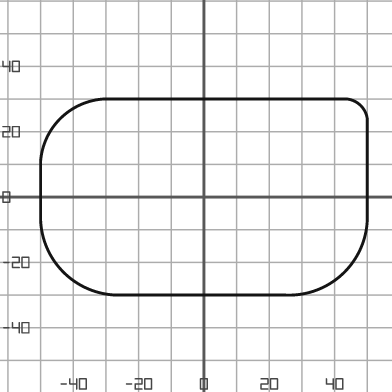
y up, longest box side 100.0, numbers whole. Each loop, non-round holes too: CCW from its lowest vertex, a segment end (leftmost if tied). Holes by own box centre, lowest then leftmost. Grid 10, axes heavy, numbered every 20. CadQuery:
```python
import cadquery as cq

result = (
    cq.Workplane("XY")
    .moveTo(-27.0, -30.0)
    .lineTo(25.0, -30.0)
    .threePointArc((43.0, -23.0), (50.0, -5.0))
    .lineTo(50.0, 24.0)
    .threePointArc((48.0, 28.0), (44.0, 30.0))
    .lineTo(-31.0, 30.0)
    .threePointArc((-44.0, 24.0), (-50.0, 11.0))
    .lineTo(-50.0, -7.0)
    .threePointArc((-43.0, -23.0), (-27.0, -30.0))
    .close()
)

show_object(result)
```